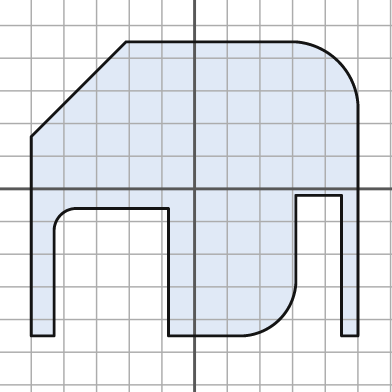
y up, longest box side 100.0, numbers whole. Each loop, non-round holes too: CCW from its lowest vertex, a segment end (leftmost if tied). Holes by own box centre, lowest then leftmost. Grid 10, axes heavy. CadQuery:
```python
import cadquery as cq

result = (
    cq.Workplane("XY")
    .moveTo(-50.0, -45.0)
    .lineTo(-43.0, -45.0)
    .lineTo(-43.0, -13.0)
    .threePointArc((-41.0, -8.0), (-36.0, -6.0))
    .lineTo(-8.0, -6.0)
    .lineTo(-8.0, -45.0)
    .lineTo(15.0, -45.0)
    .threePointArc((26.0, -40.0), (31.0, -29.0))
    .lineTo(31.0, -2.0)
    .lineTo(45.0, -2.0)
    .lineTo(45.0, -45.0)
    .lineTo(50.0, -45.0)
    .lineTo(50.0, 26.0)
    .threePointArc((44.0, 39.0), (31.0, 45.0))
    .lineTo(-21.0, 45.0)
    .lineTo(-50.0, 16.0)
    .close()
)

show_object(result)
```